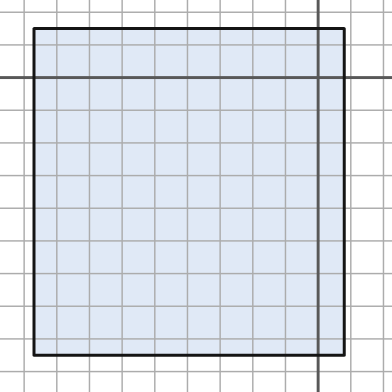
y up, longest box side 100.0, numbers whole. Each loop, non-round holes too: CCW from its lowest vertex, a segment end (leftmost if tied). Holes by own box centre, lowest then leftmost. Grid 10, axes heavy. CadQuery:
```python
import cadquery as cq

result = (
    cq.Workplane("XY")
    .moveTo(-87.0, -85.0)
    .lineTo(8.0, -85.0)
    .lineTo(8.0, 15.0)
    .lineTo(-87.0, 15.0)
    .close()
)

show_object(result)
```